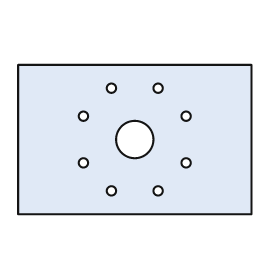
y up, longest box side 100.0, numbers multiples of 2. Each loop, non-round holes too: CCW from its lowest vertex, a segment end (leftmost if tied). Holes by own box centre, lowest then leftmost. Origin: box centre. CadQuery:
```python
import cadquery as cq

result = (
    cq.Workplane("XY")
    .moveTo(-50.0, -32.0)
    .lineTo(50.0, -32.0)
    .lineTo(50.0, 32.0)
    .lineTo(-50.0, 32.0)
    .close()
    .moveTo(-10.0, -22.0)
    .circle(2.0)
    .moveTo(10.0, -22.0)
    .circle(2.0)
    .moveTo(-22.0, -10.0)
    .circle(2.0)
    .moveTo(22.0, -10.0)
    .circle(2.0)
    .moveTo(0.0, 0.0)
    .circle(8.0)
    .moveTo(-22.0, 10.0)
    .circle(2.0)
    .moveTo(22.0, 10.0)
    .circle(2.0)
    .moveTo(-10.0, 22.0)
    .circle(2.0)
    .moveTo(10.0, 22.0)
    .circle(2.0)
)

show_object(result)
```